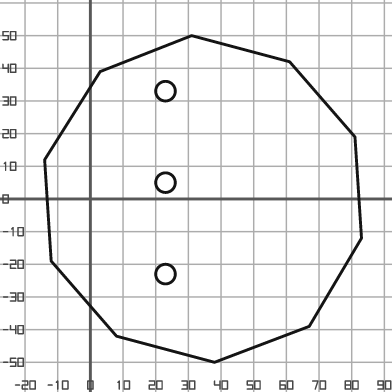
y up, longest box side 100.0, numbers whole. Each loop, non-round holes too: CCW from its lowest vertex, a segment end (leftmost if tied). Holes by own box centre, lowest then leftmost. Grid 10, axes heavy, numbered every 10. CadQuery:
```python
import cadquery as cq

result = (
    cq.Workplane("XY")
    .moveTo(38.0, -50.0)
    .lineTo(67.0, -39.0)
    .lineTo(83.0, -12.0)
    .lineTo(81.0, 19.0)
    .lineTo(61.0, 42.0)
    .lineTo(31.0, 50.0)
    .lineTo(3.0, 39.0)
    .lineTo(-14.0, 12.0)
    .lineTo(-12.0, -19.0)
    .lineTo(8.0, -42.0)
    .close()
    .moveTo(23.0, -23.0)
    .circle(3.0)
    .moveTo(23.0, 5.0)
    .circle(3.0)
    .moveTo(23.0, 33.0)
    .circle(3.0)
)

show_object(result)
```